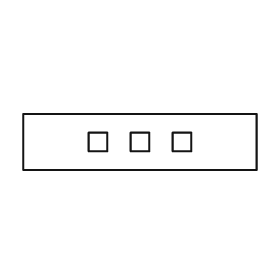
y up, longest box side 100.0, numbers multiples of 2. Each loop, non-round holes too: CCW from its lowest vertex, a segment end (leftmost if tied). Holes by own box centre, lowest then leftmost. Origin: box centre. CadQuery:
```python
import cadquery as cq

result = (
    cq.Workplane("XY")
    .moveTo(-50.0, -12.0)
    .lineTo(50.0, -12.0)
    .lineTo(50.0, 12.0)
    .lineTo(-50.0, 12.0)
    .close()
    .moveTo(-22.0, -4.0)
    .lineTo(-14.0, -4.0)
    .lineTo(-14.0, 4.0)
    .lineTo(-22.0, 4.0)
    .close()
    .moveTo(-4.0, -4.0)
    .lineTo(4.0, -4.0)
    .lineTo(4.0, 4.0)
    .lineTo(-4.0, 4.0)
    .close()
    .moveTo(14.0, -4.0)
    .lineTo(22.0, -4.0)
    .lineTo(22.0, 4.0)
    .lineTo(14.0, 4.0)
    .close()
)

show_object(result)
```